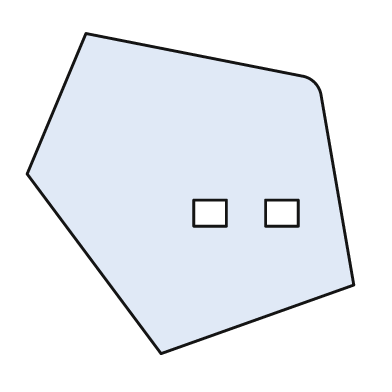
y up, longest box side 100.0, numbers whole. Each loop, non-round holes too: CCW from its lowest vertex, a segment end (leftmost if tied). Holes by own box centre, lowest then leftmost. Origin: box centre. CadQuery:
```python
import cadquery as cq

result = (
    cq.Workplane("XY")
    .moveTo(-9.0, -49.0)
    .lineTo(50.0, -28.0)
    .lineTo(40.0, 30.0)
    .threePointArc((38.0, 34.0), (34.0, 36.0))
    .lineTo(-32.0, 49.0)
    .lineTo(-50.0, 6.0)
    .close()
    .moveTo(1.0, -10.0)
    .lineTo(11.0, -10.0)
    .lineTo(11.0, -2.0)
    .lineTo(1.0, -2.0)
    .close()
    .moveTo(23.0, -10.0)
    .lineTo(33.0, -10.0)
    .lineTo(33.0, -2.0)
    .lineTo(23.0, -2.0)
    .close()
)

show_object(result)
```